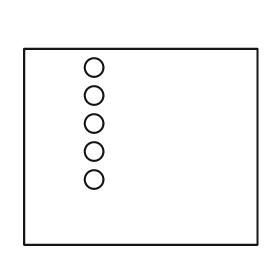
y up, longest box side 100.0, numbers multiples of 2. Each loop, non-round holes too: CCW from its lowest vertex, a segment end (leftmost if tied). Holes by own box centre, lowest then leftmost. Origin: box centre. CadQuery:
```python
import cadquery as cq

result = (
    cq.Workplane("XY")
    .moveTo(-50.0, -42.0)
    .lineTo(50.0, -42.0)
    .lineTo(50.0, 42.0)
    .lineTo(-50.0, 42.0)
    .close()
    .moveTo(-20.0, -14.0)
    .circle(4.0)
    .moveTo(-20.0, -2.0)
    .circle(4.0)
    .moveTo(-20.0, 10.0)
    .circle(4.0)
    .moveTo(-20.0, 22.0)
    .circle(4.0)
    .moveTo(-20.0, 34.0)
    .circle(4.0)
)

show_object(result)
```